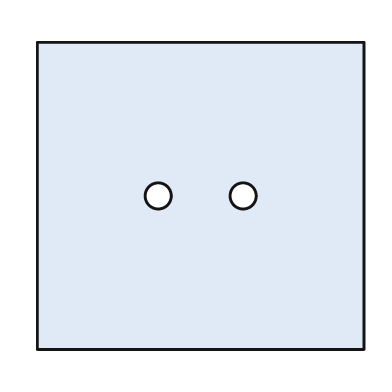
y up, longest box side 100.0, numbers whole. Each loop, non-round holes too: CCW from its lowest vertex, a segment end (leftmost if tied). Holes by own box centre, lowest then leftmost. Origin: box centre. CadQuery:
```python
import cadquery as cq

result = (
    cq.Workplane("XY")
    .moveTo(-50.0, -47.0)
    .lineTo(50.0, -47.0)
    .lineTo(50.0, 47.0)
    .lineTo(-50.0, 47.0)
    .close()
    .moveTo(-13.0, 0.0)
    .circle(4.0)
    .moveTo(13.0, 0.0)
    .circle(4.0)
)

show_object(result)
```